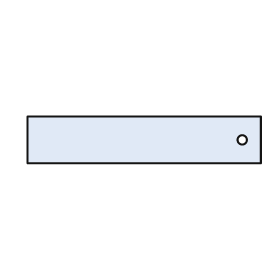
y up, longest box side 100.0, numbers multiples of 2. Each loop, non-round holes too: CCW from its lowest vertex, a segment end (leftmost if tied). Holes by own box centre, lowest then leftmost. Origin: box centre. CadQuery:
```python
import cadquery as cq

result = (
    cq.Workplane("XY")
    .moveTo(-50.0, -10.0)
    .lineTo(50.0, -10.0)
    .lineTo(50.0, 10.0)
    .lineTo(-50.0, 10.0)
    .close()
    .moveTo(42.0, 0.0)
    .circle(2.0)
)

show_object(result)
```